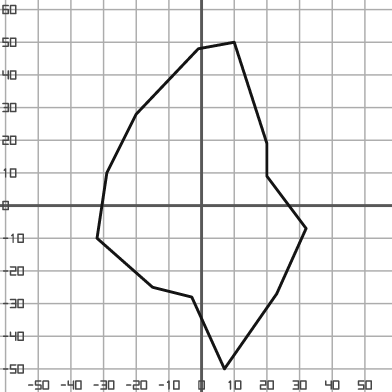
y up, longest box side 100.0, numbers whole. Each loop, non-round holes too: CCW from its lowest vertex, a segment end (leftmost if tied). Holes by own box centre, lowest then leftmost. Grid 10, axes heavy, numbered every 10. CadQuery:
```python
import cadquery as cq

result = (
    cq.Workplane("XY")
    .moveTo(7.0, -50.0)
    .lineTo(23.0, -27.0)
    .lineTo(32.0, -7.0)
    .lineTo(20.0, 9.0)
    .lineTo(20.0, 19.0)
    .lineTo(10.0, 50.0)
    .lineTo(-1.0, 48.0)
    .lineTo(-20.0, 28.0)
    .lineTo(-29.0, 10.0)
    .lineTo(-32.0, -10.0)
    .lineTo(-15.0, -25.0)
    .lineTo(-3.0, -28.0)
    .close()
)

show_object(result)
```